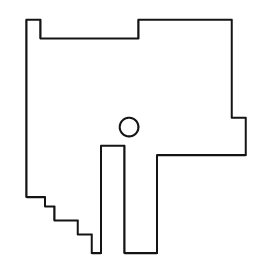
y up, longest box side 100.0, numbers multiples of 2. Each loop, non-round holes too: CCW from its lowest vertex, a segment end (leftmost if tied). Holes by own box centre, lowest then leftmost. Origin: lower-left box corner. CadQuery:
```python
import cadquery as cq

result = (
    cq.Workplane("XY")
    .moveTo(28.0, 0.0)
    .lineTo(32.0, 0.0)
    .lineTo(32.0, 46.0)
    .lineTo(42.0, 46.0)
    .lineTo(42.0, 0.0)
    .lineTo(56.0, 0.0)
    .lineTo(56.0, 42.0)
    .lineTo(94.0, 42.0)
    .lineTo(94.0, 58.0)
    .lineTo(88.0, 58.0)
    .lineTo(88.0, 100.0)
    .lineTo(48.0, 100.0)
    .lineTo(48.0, 92.0)
    .lineTo(6.0, 92.0)
    .lineTo(6.0, 100.0)
    .lineTo(0.0, 100.0)
    .lineTo(0.0, 24.0)
    .lineTo(8.0, 24.0)
    .lineTo(8.0, 20.0)
    .lineTo(12.0, 20.0)
    .lineTo(12.0, 14.0)
    .lineTo(22.0, 14.0)
    .lineTo(22.0, 8.0)
    .lineTo(28.0, 8.0)
    .close()
    .moveTo(44.0, 54.0)
    .circle(4.0)
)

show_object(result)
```